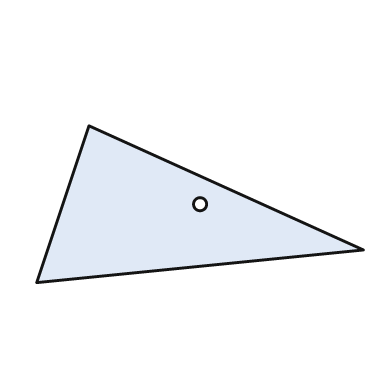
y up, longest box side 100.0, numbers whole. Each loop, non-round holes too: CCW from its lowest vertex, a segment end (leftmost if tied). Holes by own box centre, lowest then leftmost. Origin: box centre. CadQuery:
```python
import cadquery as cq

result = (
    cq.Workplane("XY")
    .moveTo(-50.0, -24.0)
    .lineTo(50.0, -14.0)
    .lineTo(-34.0, 24.0)
    .close()
    .moveTo(0.0, 0.0)
    .circle(2.0)
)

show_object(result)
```